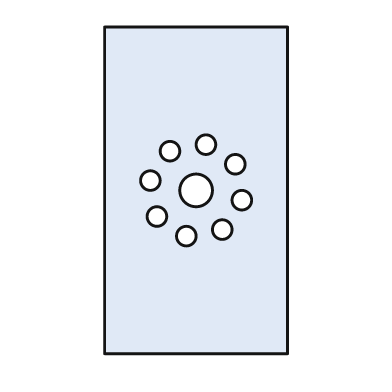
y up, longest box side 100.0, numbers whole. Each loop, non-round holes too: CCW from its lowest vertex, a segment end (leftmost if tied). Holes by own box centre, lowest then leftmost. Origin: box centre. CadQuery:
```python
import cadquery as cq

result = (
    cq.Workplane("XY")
    .moveTo(-28.0, -50.0)
    .lineTo(28.0, -50.0)
    .lineTo(28.0, 50.0)
    .lineTo(-28.0, 50.0)
    .close()
    .moveTo(-3.0, -14.0)
    .circle(3.0)
    .moveTo(8.0, -12.0)
    .circle(3.0)
    .moveTo(-12.0, -8.0)
    .circle(3.0)
    .moveTo(14.0, -3.0)
    .circle(3.0)
    .moveTo(0.0, 0.0)
    .circle(5.0)
    .moveTo(-14.0, 3.0)
    .circle(3.0)
    .moveTo(12.0, 8.0)
    .circle(3.0)
    .moveTo(-8.0, 12.0)
    .circle(3.0)
    .moveTo(3.0, 14.0)
    .circle(3.0)
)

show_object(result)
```